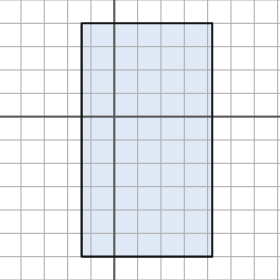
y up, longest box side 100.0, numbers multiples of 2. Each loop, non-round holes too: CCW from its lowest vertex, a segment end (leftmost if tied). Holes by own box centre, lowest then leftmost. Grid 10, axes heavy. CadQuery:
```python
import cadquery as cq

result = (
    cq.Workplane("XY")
    .moveTo(-14.0, -60.0)
    .lineTo(42.0, -60.0)
    .lineTo(42.0, 40.0)
    .lineTo(-14.0, 40.0)
    .close()
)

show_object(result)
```